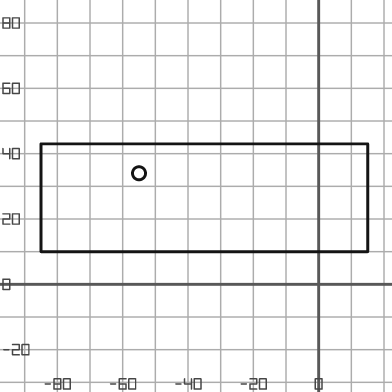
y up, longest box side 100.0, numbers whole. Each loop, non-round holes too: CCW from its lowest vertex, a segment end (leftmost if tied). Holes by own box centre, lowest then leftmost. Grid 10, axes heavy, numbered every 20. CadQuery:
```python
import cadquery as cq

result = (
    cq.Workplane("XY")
    .moveTo(-85.0, 10.0)
    .lineTo(15.0, 10.0)
    .lineTo(15.0, 43.0)
    .lineTo(-85.0, 43.0)
    .close()
    .moveTo(-55.0, 34.0)
    .circle(2.0)
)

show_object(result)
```